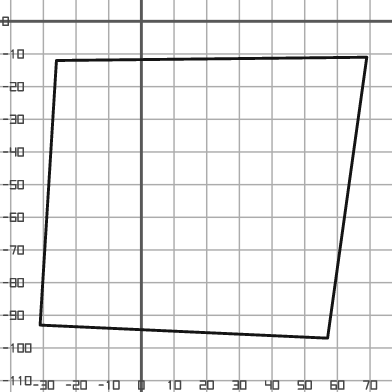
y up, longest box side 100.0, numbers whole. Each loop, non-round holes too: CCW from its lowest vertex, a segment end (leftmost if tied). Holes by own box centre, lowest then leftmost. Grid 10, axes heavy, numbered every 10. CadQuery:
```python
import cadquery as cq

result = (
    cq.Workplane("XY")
    .moveTo(57.0, -97.0)
    .lineTo(69.0, -11.0)
    .lineTo(-26.0, -12.0)
    .lineTo(-31.0, -93.0)
    .close()
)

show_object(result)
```